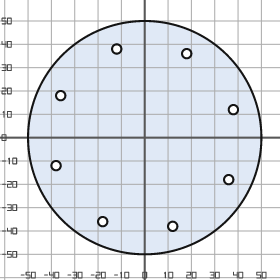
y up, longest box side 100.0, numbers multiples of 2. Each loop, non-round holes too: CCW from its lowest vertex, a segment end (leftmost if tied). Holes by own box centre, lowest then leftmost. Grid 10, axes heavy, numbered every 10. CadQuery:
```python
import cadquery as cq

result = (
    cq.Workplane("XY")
    .moveTo(0.0, 0.0)
    .circle(50.0)
    .moveTo(12.0, -38.0)
    .circle(2.0)
    .moveTo(-18.0, -36.0)
    .circle(2.0)
    .moveTo(36.0, -18.0)
    .circle(2.0)
    .moveTo(-38.0, -12.0)
    .circle(2.0)
    .moveTo(38.0, 12.0)
    .circle(2.0)
    .moveTo(-36.0, 18.0)
    .circle(2.0)
    .moveTo(18.0, 36.0)
    .circle(2.0)
    .moveTo(-12.0, 38.0)
    .circle(2.0)
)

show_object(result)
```